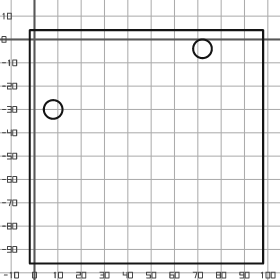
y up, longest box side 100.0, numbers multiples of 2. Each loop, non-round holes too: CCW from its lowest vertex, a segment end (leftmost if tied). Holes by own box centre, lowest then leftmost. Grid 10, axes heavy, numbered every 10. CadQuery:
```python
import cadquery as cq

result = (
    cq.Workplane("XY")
    .moveTo(-2.0, -96.0)
    .lineTo(98.0, -96.0)
    .lineTo(98.0, 4.0)
    .lineTo(-2.0, 4.0)
    .close()
    .moveTo(8.0, -30.0)
    .circle(4.0)
    .moveTo(72.0, -4.0)
    .circle(4.0)
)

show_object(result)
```